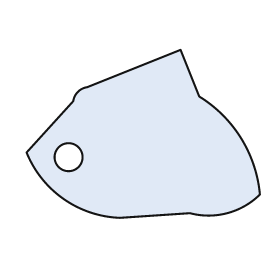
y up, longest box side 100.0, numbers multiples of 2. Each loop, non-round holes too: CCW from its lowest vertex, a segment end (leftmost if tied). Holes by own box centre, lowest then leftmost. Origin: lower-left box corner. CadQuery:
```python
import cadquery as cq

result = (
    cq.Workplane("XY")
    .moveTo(40.0, 0.0)
    .lineTo(70.0, 2.0)
    .threePointArc((86.0, 2.0), (100.0, 10.0))
    .threePointArc((92.0, 34.0), (74.0, 52.0))
    .lineTo(66.0, 72.0)
    .lineTo(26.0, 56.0)
    .threePointArc((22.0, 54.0), (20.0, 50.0))
    .lineTo(0.0, 28.0)
    .threePointArc((16.0, 8.0), (40.0, 0.0))
    .close()
    .moveTo(18.0, 26.0)
    .circle(6.0)
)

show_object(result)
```